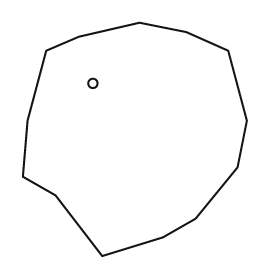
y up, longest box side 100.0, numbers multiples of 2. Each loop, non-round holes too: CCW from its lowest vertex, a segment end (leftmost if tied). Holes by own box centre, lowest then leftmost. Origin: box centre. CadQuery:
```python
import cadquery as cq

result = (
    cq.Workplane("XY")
    .moveTo(-14.0, -50.0)
    .lineTo(12.0, -42.0)
    .lineTo(26.0, -34.0)
    .lineTo(44.0, -12.0)
    .lineTo(48.0, 8.0)
    .lineTo(40.0, 38.0)
    .lineTo(22.0, 46.0)
    .lineTo(2.0, 50.0)
    .lineTo(-24.0, 44.0)
    .lineTo(-38.0, 38.0)
    .lineTo(-46.0, 8.0)
    .lineTo(-48.0, -16.0)
    .lineTo(-34.0, -24.0)
    .close()
    .moveTo(-18.0, 24.0)
    .circle(2.0)
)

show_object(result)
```